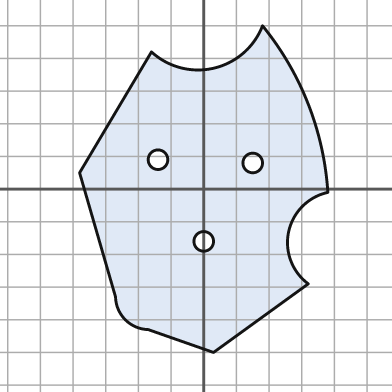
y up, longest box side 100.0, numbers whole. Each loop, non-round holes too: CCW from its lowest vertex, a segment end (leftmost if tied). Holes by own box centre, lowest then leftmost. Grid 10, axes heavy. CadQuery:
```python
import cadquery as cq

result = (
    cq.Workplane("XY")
    .moveTo(3.0, -50.0)
    .lineTo(32.0, -29.0)
    .threePointArc((26.0, -13.0), (38.0, -1.0))
    .threePointArc((32.0, 26.0), (18.0, 50.0))
    .threePointArc((3.0, 37.0), (-16.0, 42.0))
    .lineTo(-38.0, 5.0)
    .lineTo(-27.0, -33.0)
    .threePointArc((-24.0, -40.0), (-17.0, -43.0))
    .close()
    .moveTo(0.0, -16.0)
    .circle(3.0)
    .moveTo(15.0, 8.0)
    .circle(3.0)
    .moveTo(-14.0, 9.0)
    .circle(3.0)
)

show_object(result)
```